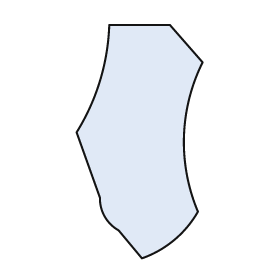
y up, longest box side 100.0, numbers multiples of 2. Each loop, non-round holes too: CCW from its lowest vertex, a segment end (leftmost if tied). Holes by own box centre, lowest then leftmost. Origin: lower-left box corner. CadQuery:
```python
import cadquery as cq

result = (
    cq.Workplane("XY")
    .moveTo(28.0, 0.0)
    .threePointArc((42.0, 8.0), (52.0, 20.0))
    .threePointArc((46.0, 52.0), (54.0, 84.0))
    .lineTo(40.0, 100.0)
    .lineTo(14.0, 100.0)
    .threePointArc((10.0, 76.0), (0.0, 54.0))
    .lineTo(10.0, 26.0)
    .threePointArc((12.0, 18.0), (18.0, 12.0))
    .close()
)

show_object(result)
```